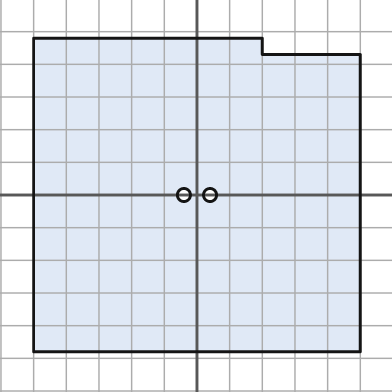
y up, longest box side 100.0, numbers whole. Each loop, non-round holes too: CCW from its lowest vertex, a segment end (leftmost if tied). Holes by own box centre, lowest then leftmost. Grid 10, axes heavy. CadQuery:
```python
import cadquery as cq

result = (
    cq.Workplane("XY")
    .moveTo(-50.0, -48.0)
    .lineTo(50.0, -48.0)
    .lineTo(50.0, 43.0)
    .lineTo(20.0, 43.0)
    .lineTo(20.0, 48.0)
    .lineTo(-50.0, 48.0)
    .close()
    .moveTo(-4.0, 0.0)
    .circle(2.0)
    .moveTo(4.0, 0.0)
    .circle(2.0)
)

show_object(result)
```